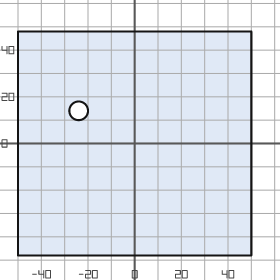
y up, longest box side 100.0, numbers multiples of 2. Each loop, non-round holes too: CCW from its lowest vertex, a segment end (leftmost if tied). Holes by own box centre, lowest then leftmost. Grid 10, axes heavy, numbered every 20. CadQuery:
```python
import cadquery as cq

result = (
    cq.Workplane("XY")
    .moveTo(-50.0, -48.0)
    .lineTo(50.0, -48.0)
    .lineTo(50.0, 48.0)
    .lineTo(-50.0, 48.0)
    .close()
    .moveTo(-24.0, 14.0)
    .circle(4.0)
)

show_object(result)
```